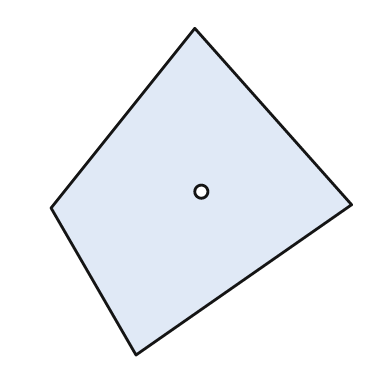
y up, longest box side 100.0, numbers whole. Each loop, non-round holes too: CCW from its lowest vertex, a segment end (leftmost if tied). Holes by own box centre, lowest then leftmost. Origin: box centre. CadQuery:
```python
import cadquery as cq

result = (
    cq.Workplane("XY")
    .moveTo(-20.0, -50.0)
    .lineTo(46.0, -4.0)
    .lineTo(-2.0, 50.0)
    .lineTo(-46.0, -5.0)
    .close()
    .moveTo(0.0, 0.0)
    .circle(2.0)
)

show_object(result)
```